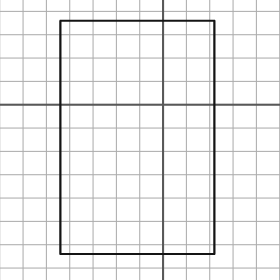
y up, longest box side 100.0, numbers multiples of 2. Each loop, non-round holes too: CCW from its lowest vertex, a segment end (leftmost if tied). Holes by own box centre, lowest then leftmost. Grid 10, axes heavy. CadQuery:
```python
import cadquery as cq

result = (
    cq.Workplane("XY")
    .moveTo(-44.0, -64.0)
    .lineTo(22.0, -64.0)
    .lineTo(22.0, 36.0)
    .lineTo(-44.0, 36.0)
    .close()
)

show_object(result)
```